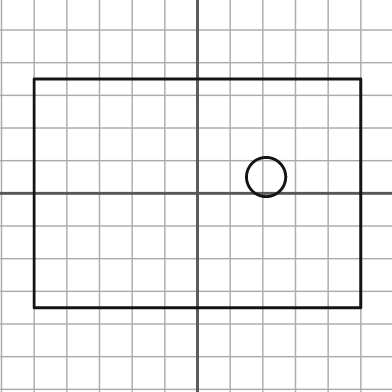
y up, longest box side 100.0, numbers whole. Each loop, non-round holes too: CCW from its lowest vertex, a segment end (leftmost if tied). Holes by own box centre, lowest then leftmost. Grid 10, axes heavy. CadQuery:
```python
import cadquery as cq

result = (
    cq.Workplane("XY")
    .moveTo(-50.0, -35.0)
    .lineTo(50.0, -35.0)
    .lineTo(50.0, 35.0)
    .lineTo(-50.0, 35.0)
    .close()
    .moveTo(21.0, 5.0)
    .circle(6.0)
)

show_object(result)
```